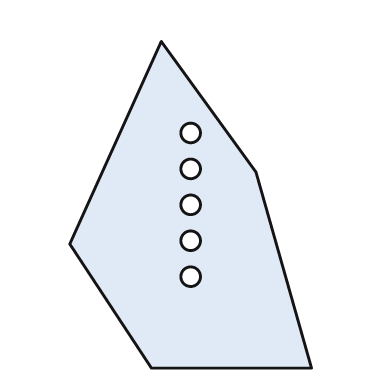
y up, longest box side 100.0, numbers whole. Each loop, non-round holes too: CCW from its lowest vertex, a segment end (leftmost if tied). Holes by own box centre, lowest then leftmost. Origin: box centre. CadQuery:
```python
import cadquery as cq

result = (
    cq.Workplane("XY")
    .moveTo(-12.0, -50.0)
    .lineTo(37.0, -50.0)
    .lineTo(20.0, 10.0)
    .lineTo(-9.0, 50.0)
    .lineTo(-37.0, -12.0)
    .close()
    .moveTo(0.0, -22.0)
    .circle(3.0)
    .moveTo(0.0, -11.0)
    .circle(3.0)
    .moveTo(0.0, 0.0)
    .circle(3.0)
    .moveTo(0.0, 11.0)
    .circle(3.0)
    .moveTo(0.0, 22.0)
    .circle(3.0)
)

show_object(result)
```